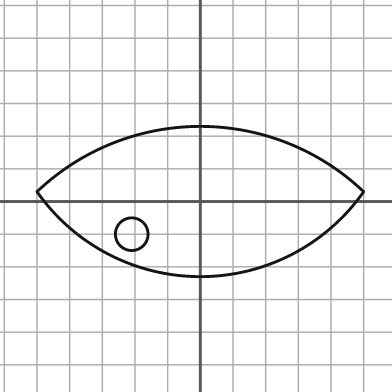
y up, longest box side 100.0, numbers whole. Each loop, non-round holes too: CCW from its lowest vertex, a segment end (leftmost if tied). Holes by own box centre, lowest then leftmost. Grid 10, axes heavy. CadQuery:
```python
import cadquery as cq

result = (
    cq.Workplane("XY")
    .moveTo(-50.0, 3.0)
    .threePointArc((0.0, -23.0), (50.0, 3.0))
    .threePointArc((0.0, 23.0), (-50.0, 3.0))
    .close()
    .moveTo(-21.0, -10.0)
    .circle(5.0)
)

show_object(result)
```